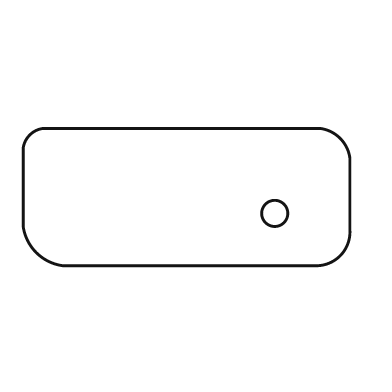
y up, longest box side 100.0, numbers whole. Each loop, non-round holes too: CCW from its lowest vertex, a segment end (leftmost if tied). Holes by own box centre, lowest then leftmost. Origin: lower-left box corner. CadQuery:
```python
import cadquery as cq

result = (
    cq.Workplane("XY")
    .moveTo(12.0, 0.0)
    .lineTo(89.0, 0.0)
    .threePointArc((97.0, 3.0), (100.0, 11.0))
    .lineTo(100.0, 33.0)
    .threePointArc((97.0, 39.0), (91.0, 42.0))
    .lineTo(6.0, 42.0)
    .threePointArc((2.0, 40.0), (0.0, 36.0))
    .lineTo(0.0, 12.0)
    .threePointArc((4.0, 4.0), (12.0, 0.0))
    .close()
    .moveTo(77.0, 16.0)
    .circle(4.0)
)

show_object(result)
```